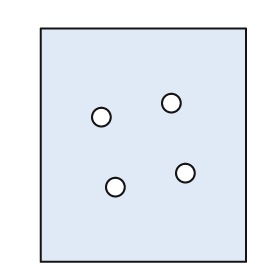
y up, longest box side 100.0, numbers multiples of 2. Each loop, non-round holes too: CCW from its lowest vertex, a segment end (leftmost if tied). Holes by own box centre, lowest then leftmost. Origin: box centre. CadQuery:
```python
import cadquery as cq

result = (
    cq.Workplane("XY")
    .moveTo(-44.0, -50.0)
    .lineTo(44.0, -50.0)
    .lineTo(44.0, 50.0)
    .lineTo(-44.0, 50.0)
    .close()
    .moveTo(-12.0, -18.0)
    .circle(4.0)
    .moveTo(18.0, -12.0)
    .circle(4.0)
    .moveTo(-18.0, 12.0)
    .circle(4.0)
    .moveTo(12.0, 18.0)
    .circle(4.0)
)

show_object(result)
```